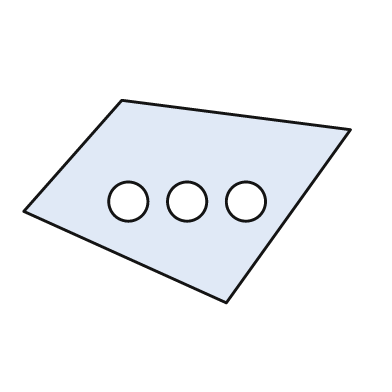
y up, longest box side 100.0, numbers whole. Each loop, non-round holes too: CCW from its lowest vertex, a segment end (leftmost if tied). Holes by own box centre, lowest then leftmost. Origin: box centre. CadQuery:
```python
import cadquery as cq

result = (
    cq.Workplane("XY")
    .moveTo(12.0, -31.0)
    .lineTo(50.0, 22.0)
    .lineTo(-20.0, 31.0)
    .lineTo(-50.0, -3.0)
    .close()
    .moveTo(-18.0, 0.0)
    .circle(6.0)
    .moveTo(0.0, 0.0)
    .circle(6.0)
    .moveTo(18.0, 0.0)
    .circle(6.0)
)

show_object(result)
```